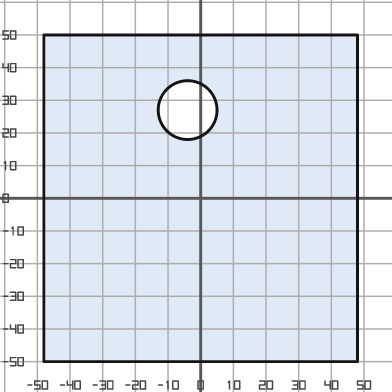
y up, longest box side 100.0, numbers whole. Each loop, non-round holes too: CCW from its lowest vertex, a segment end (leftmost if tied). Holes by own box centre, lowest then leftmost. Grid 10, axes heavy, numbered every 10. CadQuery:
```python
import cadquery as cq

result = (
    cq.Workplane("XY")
    .moveTo(-48.0, -50.0)
    .lineTo(48.0, -50.0)
    .lineTo(48.0, 50.0)
    .lineTo(-48.0, 50.0)
    .close()
    .moveTo(-4.0, 27.0)
    .circle(9.0)
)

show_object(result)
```